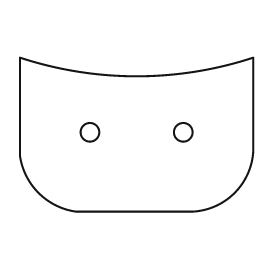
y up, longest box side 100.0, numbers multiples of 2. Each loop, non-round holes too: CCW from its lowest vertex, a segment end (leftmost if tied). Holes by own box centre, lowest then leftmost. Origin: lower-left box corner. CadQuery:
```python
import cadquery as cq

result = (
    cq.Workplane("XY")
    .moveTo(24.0, 0.0)
    .lineTo(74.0, 0.0)
    .threePointArc((92.0, 8.0), (100.0, 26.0))
    .lineTo(100.0, 66.0)
    .threePointArc((50.0, 58.0), (0.0, 66.0))
    .lineTo(0.0, 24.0)
    .threePointArc((8.0, 8.0), (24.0, 0.0))
    .close()
    .moveTo(30.0, 34.0)
    .circle(4.0)
    .moveTo(70.0, 34.0)
    .circle(4.0)
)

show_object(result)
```